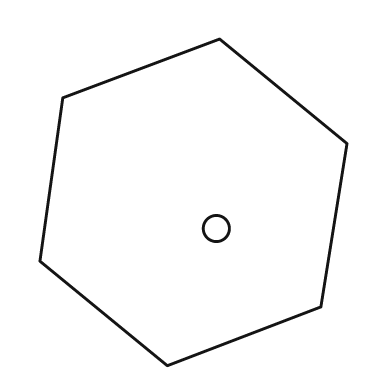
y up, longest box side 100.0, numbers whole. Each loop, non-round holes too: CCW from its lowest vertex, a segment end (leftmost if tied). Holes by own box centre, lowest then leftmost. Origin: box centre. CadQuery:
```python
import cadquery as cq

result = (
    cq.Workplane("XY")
    .moveTo(-8.0, -50.0)
    .lineTo(39.0, -32.0)
    .lineTo(47.0, 18.0)
    .lineTo(8.0, 50.0)
    .lineTo(-40.0, 32.0)
    .lineTo(-47.0, -18.0)
    .close()
    .moveTo(7.0, -8.0)
    .circle(4.0)
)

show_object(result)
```